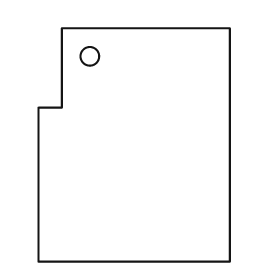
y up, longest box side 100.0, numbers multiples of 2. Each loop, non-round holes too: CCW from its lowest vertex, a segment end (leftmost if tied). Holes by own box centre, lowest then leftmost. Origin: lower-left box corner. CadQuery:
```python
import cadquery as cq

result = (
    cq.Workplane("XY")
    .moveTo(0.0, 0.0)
    .lineTo(82.0, 0.0)
    .lineTo(82.0, 100.0)
    .lineTo(10.0, 100.0)
    .lineTo(10.0, 66.0)
    .lineTo(0.0, 66.0)
    .close()
    .moveTo(22.0, 88.0)
    .circle(4.0)
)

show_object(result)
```